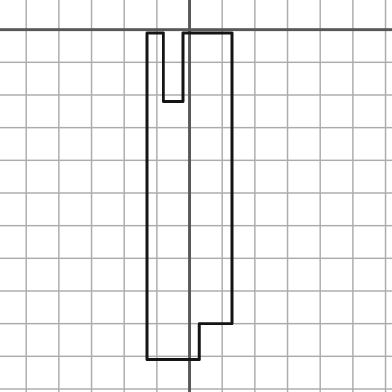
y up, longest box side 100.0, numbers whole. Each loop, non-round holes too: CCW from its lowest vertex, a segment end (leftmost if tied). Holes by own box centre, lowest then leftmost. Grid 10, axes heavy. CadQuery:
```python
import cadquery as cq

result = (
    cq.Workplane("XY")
    .moveTo(-13.0, -101.0)
    .lineTo(3.0, -101.0)
    .lineTo(3.0, -90.0)
    .lineTo(13.0, -90.0)
    .lineTo(13.0, -1.0)
    .lineTo(-2.0, -1.0)
    .lineTo(-2.0, -22.0)
    .lineTo(-8.0, -22.0)
    .lineTo(-8.0, -1.0)
    .lineTo(-13.0, -1.0)
    .close()
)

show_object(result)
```